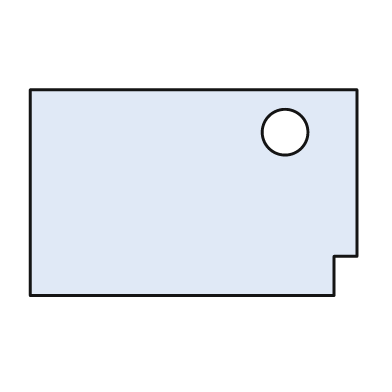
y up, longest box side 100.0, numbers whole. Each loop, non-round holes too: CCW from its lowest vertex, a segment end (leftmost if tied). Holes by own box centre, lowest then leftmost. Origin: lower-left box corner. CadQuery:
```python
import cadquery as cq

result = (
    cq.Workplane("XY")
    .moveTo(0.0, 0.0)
    .lineTo(93.0, 0.0)
    .lineTo(93.0, 12.0)
    .lineTo(100.0, 12.0)
    .lineTo(100.0, 63.0)
    .lineTo(0.0, 63.0)
    .close()
    .moveTo(78.0, 50.0)
    .circle(7.0)
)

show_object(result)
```